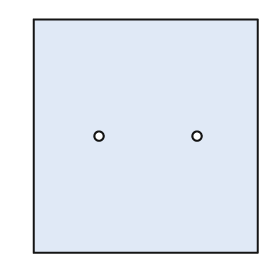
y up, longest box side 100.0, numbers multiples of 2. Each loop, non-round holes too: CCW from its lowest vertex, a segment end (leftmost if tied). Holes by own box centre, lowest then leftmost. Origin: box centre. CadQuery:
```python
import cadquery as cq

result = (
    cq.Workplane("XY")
    .moveTo(-48.0, -50.0)
    .lineTo(48.0, -50.0)
    .lineTo(48.0, 50.0)
    .lineTo(-48.0, 50.0)
    .close()
    .moveTo(-20.0, 0.0)
    .circle(2.0)
    .moveTo(22.0, 0.0)
    .circle(2.0)
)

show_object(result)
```